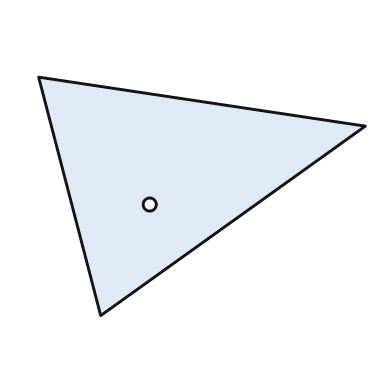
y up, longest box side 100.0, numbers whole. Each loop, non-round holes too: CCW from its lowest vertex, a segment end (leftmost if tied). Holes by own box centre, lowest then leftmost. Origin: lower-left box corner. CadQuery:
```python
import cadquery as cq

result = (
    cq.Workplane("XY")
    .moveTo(19.0, 0.0)
    .lineTo(100.0, 58.0)
    .lineTo(0.0, 73.0)
    .close()
    .moveTo(34.0, 34.0)
    .circle(2.0)
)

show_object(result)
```